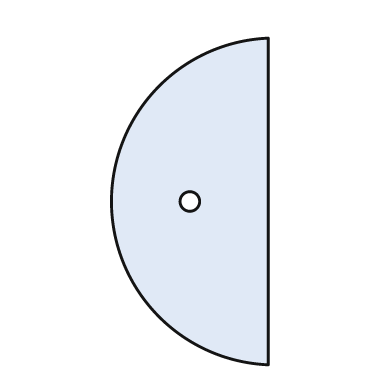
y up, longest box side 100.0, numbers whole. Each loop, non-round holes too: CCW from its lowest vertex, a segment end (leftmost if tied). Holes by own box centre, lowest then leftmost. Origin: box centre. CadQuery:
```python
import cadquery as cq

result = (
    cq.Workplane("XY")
    .moveTo(24.0, -50.0)
    .lineTo(24.0, 50.0)
    .threePointArc((-24.0, 0.0), (24.0, -50.0))
    .close()
    .moveTo(0.0, 0.0)
    .circle(3.0)
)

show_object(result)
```